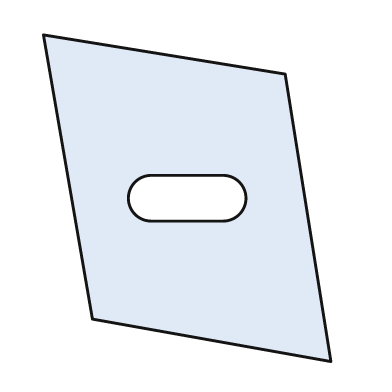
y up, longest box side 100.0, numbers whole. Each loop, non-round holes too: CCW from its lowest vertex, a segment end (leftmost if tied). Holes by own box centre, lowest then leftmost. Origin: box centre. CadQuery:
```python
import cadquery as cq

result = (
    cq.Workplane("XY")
    .moveTo(44.0, -50.0)
    .lineTo(30.0, 38.0)
    .lineTo(-44.0, 50.0)
    .lineTo(-29.0, -37.0)
    .close()
    .moveTo(-11.0, -7.0)
    .lineTo(11.0, -7.0)
    .threePointArc((18.0, 0.0), (11.0, 7.0))
    .lineTo(-11.0, 7.0)
    .threePointArc((-18.0, 0.0), (-11.0, -7.0))
    .close()
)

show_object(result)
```